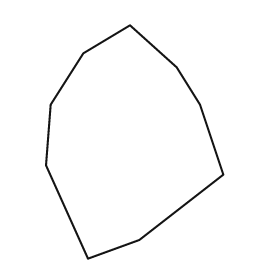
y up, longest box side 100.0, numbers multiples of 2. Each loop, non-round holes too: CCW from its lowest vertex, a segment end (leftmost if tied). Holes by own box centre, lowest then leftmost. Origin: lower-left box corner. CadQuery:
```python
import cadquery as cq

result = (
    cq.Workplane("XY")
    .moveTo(18.0, 0.0)
    .lineTo(40.0, 8.0)
    .lineTo(76.0, 36.0)
    .lineTo(66.0, 66.0)
    .lineTo(56.0, 82.0)
    .lineTo(36.0, 100.0)
    .lineTo(16.0, 88.0)
    .lineTo(2.0, 66.0)
    .lineTo(0.0, 40.0)
    .close()
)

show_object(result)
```